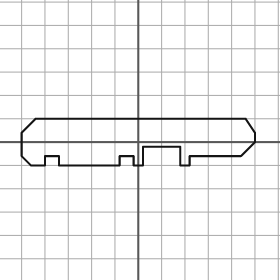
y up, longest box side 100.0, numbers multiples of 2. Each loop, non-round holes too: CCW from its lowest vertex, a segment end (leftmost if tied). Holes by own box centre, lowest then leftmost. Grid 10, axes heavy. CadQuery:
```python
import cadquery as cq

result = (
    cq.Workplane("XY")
    .moveTo(-46.0, -10.0)
    .lineTo(-40.0, -10.0)
    .lineTo(-40.0, -6.0)
    .lineTo(-34.0, -6.0)
    .lineTo(-34.0, -10.0)
    .lineTo(-8.0, -10.0)
    .lineTo(-8.0, -6.0)
    .lineTo(-2.0, -6.0)
    .lineTo(-2.0, -10.0)
    .lineTo(2.0, -10.0)
    .lineTo(2.0, -2.0)
    .lineTo(18.0, -2.0)
    .lineTo(18.0, -10.0)
    .lineTo(22.0, -10.0)
    .lineTo(22.0, -6.0)
    .lineTo(44.0, -6.0)
    .lineTo(50.0, 0.0)
    .lineTo(50.0, 4.0)
    .lineTo(46.0, 10.0)
    .lineTo(-44.0, 10.0)
    .lineTo(-50.0, 4.0)
    .lineTo(-50.0, -6.0)
    .close()
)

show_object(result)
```